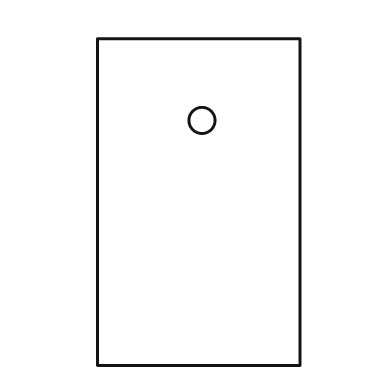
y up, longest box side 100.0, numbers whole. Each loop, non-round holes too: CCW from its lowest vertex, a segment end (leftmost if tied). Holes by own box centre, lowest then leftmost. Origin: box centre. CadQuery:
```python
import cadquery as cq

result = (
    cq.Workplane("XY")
    .moveTo(-31.0, -50.0)
    .lineTo(31.0, -50.0)
    .lineTo(31.0, 50.0)
    .lineTo(-31.0, 50.0)
    .close()
    .moveTo(1.0, 25.0)
    .circle(4.0)
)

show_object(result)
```